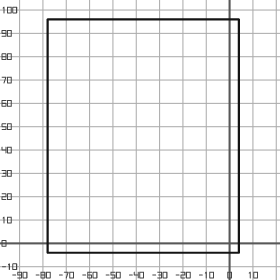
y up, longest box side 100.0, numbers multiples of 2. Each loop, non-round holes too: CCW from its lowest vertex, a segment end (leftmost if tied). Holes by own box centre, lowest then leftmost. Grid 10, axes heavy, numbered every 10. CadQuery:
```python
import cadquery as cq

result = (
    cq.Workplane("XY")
    .moveTo(-78.0, -4.0)
    .lineTo(4.0, -4.0)
    .lineTo(4.0, 96.0)
    .lineTo(-78.0, 96.0)
    .close()
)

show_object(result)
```